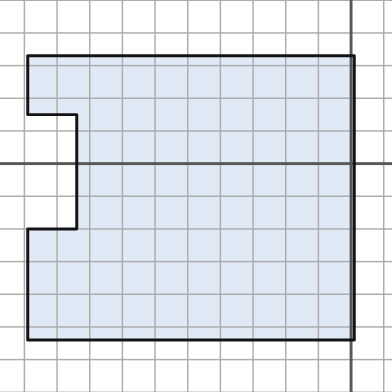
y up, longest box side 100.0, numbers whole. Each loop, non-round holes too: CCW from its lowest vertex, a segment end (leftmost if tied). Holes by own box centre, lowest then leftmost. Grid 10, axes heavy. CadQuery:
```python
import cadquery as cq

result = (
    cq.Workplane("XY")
    .moveTo(-99.0, -54.0)
    .lineTo(1.0, -54.0)
    .lineTo(1.0, 33.0)
    .lineTo(-99.0, 33.0)
    .lineTo(-99.0, 15.0)
    .lineTo(-84.0, 15.0)
    .lineTo(-84.0, -20.0)
    .lineTo(-99.0, -20.0)
    .close()
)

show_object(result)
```